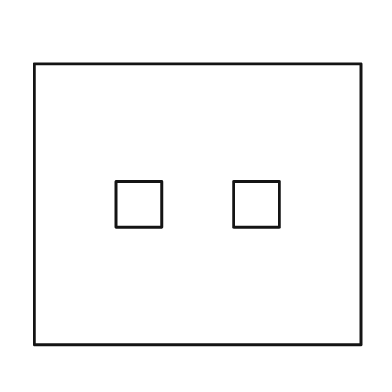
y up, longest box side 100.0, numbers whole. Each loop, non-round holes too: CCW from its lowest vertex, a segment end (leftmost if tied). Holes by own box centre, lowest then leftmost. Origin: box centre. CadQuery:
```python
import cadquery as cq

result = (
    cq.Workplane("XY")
    .moveTo(-50.0, -43.0)
    .lineTo(50.0, -43.0)
    .lineTo(50.0, 43.0)
    .lineTo(-50.0, 43.0)
    .close()
    .moveTo(-25.0, -7.0)
    .lineTo(-11.0, -7.0)
    .lineTo(-11.0, 7.0)
    .lineTo(-25.0, 7.0)
    .close()
    .moveTo(11.0, -7.0)
    .lineTo(25.0, -7.0)
    .lineTo(25.0, 7.0)
    .lineTo(11.0, 7.0)
    .close()
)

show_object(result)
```